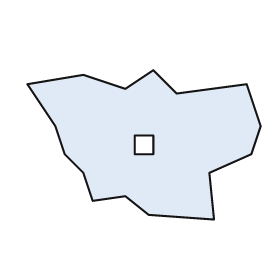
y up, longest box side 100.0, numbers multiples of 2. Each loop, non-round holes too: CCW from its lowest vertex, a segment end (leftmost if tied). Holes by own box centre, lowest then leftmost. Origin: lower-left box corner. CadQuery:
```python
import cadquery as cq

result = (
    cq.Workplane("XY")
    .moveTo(80.0, 0.0)
    .lineTo(78.0, 20.0)
    .lineTo(96.0, 28.0)
    .lineTo(100.0, 40.0)
    .lineTo(94.0, 58.0)
    .lineTo(64.0, 54.0)
    .lineTo(54.0, 64.0)
    .lineTo(42.0, 56.0)
    .lineTo(24.0, 62.0)
    .lineTo(0.0, 58.0)
    .lineTo(12.0, 40.0)
    .lineTo(16.0, 28.0)
    .lineTo(24.0, 20.0)
    .lineTo(28.0, 8.0)
    .lineTo(42.0, 10.0)
    .lineTo(52.0, 2.0)
    .close()
    .moveTo(46.0, 28.0)
    .lineTo(54.0, 28.0)
    .lineTo(54.0, 36.0)
    .lineTo(46.0, 36.0)
    .close()
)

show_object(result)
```